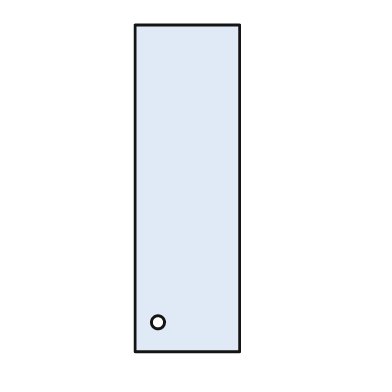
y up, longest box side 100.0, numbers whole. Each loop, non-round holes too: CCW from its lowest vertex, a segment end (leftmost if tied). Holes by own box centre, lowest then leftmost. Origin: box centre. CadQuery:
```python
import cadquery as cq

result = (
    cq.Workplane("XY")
    .moveTo(-16.0, -50.0)
    .lineTo(16.0, -50.0)
    .lineTo(16.0, 50.0)
    .lineTo(-16.0, 50.0)
    .close()
    .moveTo(-9.0, -41.0)
    .circle(2.0)
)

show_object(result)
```